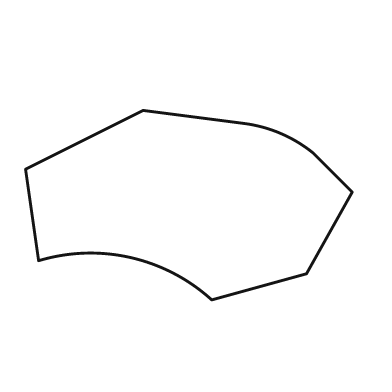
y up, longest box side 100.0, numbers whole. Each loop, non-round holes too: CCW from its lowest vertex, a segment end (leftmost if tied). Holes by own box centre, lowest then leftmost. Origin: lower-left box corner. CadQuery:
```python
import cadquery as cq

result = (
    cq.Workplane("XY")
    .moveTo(57.0, 0.0)
    .lineTo(86.0, 8.0)
    .lineTo(100.0, 33.0)
    .lineTo(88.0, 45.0)
    .threePointArc((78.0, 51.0), (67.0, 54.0))
    .lineTo(36.0, 58.0)
    .lineTo(0.0, 40.0)
    .lineTo(4.0, 12.0)
    .threePointArc((32.0, 13.0), (57.0, 0.0))
    .close()
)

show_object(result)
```